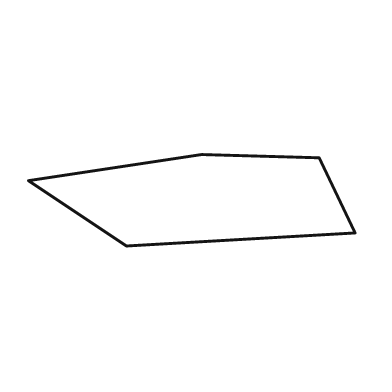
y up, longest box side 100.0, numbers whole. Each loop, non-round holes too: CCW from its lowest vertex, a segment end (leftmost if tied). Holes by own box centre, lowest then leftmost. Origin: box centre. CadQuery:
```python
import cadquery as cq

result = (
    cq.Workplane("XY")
    .moveTo(-20.0, -14.0)
    .lineTo(50.0, -10.0)
    .lineTo(39.0, 13.0)
    .lineTo(3.0, 14.0)
    .lineTo(-50.0, 6.0)
    .close()
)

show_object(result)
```